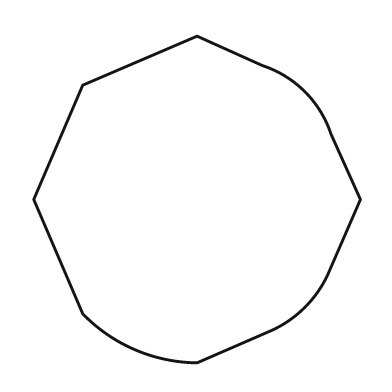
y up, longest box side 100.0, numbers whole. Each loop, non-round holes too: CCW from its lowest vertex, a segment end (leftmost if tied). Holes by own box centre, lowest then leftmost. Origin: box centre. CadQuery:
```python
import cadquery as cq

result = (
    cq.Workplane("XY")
    .moveTo(0.0, -50.0)
    .lineTo(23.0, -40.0)
    .threePointArc((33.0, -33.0), (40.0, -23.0))
    .lineTo(50.0, 0.0)
    .lineTo(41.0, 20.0)
    .threePointArc((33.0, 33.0), (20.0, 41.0))
    .lineTo(0.0, 50.0)
    .lineTo(-35.0, 35.0)
    .lineTo(-50.0, 0.0)
    .lineTo(-35.0, -35.0)
    .threePointArc((-19.0, -46.0), (0.0, -50.0))
    .close()
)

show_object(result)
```